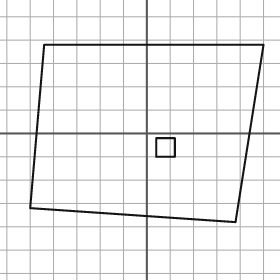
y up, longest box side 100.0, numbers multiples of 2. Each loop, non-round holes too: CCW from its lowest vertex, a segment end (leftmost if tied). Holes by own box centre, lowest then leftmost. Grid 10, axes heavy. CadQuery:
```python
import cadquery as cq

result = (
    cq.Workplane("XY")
    .moveTo(38.0, -38.0)
    .lineTo(50.0, 38.0)
    .lineTo(-44.0, 38.0)
    .lineTo(-50.0, -32.0)
    .close()
    .moveTo(4.0, -10.0)
    .lineTo(12.0, -10.0)
    .lineTo(12.0, -2.0)
    .lineTo(4.0, -2.0)
    .close()
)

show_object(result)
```